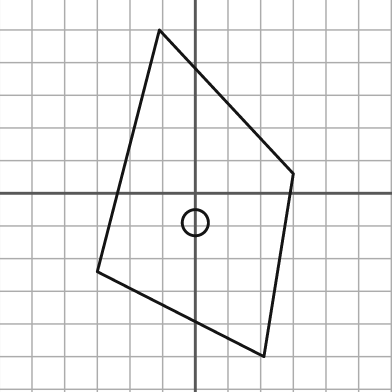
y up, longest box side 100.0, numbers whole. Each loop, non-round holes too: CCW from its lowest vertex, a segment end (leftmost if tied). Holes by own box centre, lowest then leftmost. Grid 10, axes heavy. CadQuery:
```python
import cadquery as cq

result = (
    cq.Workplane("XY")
    .moveTo(21.0, -50.0)
    .lineTo(30.0, 6.0)
    .lineTo(-11.0, 50.0)
    .lineTo(-30.0, -24.0)
    .close()
    .moveTo(0.0, -9.0)
    .circle(4.0)
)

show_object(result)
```